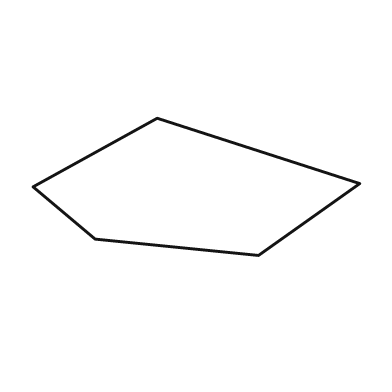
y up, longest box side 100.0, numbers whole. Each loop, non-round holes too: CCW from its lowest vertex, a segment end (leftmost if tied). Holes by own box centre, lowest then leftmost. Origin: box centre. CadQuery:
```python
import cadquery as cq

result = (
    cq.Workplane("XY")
    .moveTo(19.0, -21.0)
    .lineTo(50.0, 1.0)
    .lineTo(-12.0, 21.0)
    .lineTo(-50.0, 0.0)
    .lineTo(-31.0, -16.0)
    .close()
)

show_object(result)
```